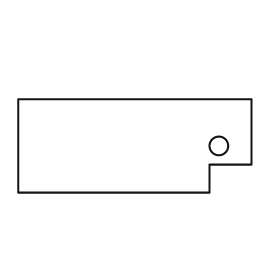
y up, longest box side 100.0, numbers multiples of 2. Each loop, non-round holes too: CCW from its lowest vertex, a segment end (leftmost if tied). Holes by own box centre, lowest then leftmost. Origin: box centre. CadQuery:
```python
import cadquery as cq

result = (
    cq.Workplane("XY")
    .moveTo(-50.0, -20.0)
    .lineTo(32.0, -20.0)
    .lineTo(32.0, -8.0)
    .lineTo(50.0, -8.0)
    .lineTo(50.0, 20.0)
    .lineTo(-50.0, 20.0)
    .close()
    .moveTo(36.0, 0.0)
    .circle(4.0)
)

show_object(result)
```